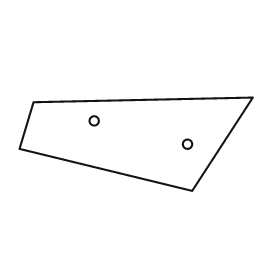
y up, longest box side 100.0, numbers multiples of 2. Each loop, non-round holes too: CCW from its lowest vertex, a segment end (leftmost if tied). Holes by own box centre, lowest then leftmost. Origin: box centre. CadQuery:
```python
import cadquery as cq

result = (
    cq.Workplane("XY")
    .moveTo(24.0, -20.0)
    .lineTo(50.0, 20.0)
    .lineTo(-44.0, 18.0)
    .lineTo(-50.0, -2.0)
    .close()
    .moveTo(22.0, 0.0)
    .circle(2.0)
    .moveTo(-18.0, 10.0)
    .circle(2.0)
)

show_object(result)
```